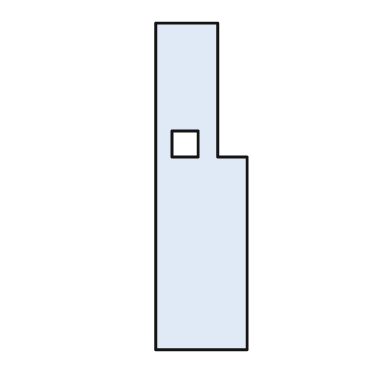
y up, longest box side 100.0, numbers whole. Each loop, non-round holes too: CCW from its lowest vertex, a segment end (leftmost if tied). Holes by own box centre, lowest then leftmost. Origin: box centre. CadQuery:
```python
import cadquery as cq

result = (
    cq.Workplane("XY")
    .moveTo(-14.0, -50.0)
    .lineTo(14.0, -50.0)
    .lineTo(14.0, 9.0)
    .lineTo(5.0, 9.0)
    .lineTo(5.0, 50.0)
    .lineTo(-14.0, 50.0)
    .close()
    .moveTo(-9.0, 9.0)
    .lineTo(-1.0, 9.0)
    .lineTo(-1.0, 17.0)
    .lineTo(-9.0, 17.0)
    .close()
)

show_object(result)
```